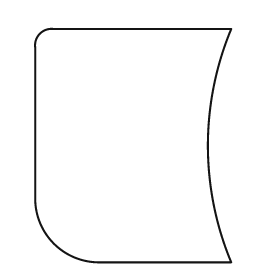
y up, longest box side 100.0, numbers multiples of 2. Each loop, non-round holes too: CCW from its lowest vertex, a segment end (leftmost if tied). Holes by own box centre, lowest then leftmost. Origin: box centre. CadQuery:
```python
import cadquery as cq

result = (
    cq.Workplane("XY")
    .moveTo(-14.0, -50.0)
    .lineTo(42.0, -50.0)
    .threePointArc((32.0, 0.0), (42.0, 50.0))
    .lineTo(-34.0, 50.0)
    .threePointArc((-40.0, 48.0), (-42.0, 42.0))
    .lineTo(-42.0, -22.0)
    .threePointArc((-34.0, -42.0), (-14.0, -50.0))
    .close()
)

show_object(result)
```